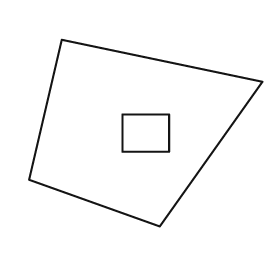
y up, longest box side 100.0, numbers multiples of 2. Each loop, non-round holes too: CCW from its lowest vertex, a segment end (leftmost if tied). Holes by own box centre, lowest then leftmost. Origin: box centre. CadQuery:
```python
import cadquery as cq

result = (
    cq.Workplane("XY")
    .moveTo(6.0, -40.0)
    .lineTo(50.0, 22.0)
    .lineTo(-36.0, 40.0)
    .lineTo(-50.0, -20.0)
    .close()
    .moveTo(-10.0, -8.0)
    .lineTo(10.0, -8.0)
    .lineTo(10.0, 8.0)
    .lineTo(-10.0, 8.0)
    .close()
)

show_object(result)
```